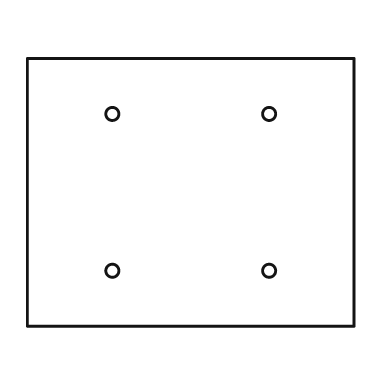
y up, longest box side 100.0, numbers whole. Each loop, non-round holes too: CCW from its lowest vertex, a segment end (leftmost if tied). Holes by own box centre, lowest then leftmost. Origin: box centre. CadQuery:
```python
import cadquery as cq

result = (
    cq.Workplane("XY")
    .moveTo(-50.0, -41.0)
    .lineTo(50.0, -41.0)
    .lineTo(50.0, 41.0)
    .lineTo(-50.0, 41.0)
    .close()
    .moveTo(-24.0, -24.0)
    .circle(2.0)
    .moveTo(24.0, -24.0)
    .circle(2.0)
    .moveTo(-24.0, 24.0)
    .circle(2.0)
    .moveTo(24.0, 24.0)
    .circle(2.0)
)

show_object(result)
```